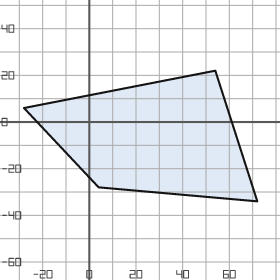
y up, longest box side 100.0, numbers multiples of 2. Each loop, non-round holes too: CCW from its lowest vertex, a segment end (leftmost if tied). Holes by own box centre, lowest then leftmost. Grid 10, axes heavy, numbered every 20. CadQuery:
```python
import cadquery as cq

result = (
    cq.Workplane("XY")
    .moveTo(72.0, -34.0)
    .lineTo(54.0, 22.0)
    .lineTo(-28.0, 6.0)
    .lineTo(4.0, -28.0)
    .close()
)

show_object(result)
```